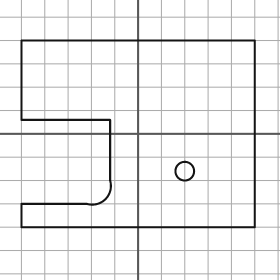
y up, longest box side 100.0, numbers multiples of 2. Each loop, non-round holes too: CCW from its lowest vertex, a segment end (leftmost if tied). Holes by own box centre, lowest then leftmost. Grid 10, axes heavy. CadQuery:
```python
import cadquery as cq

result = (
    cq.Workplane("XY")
    .moveTo(-50.0, -40.0)
    .lineTo(50.0, -40.0)
    .lineTo(50.0, 40.0)
    .lineTo(-50.0, 40.0)
    .lineTo(-50.0, 6.0)
    .lineTo(-12.0, 6.0)
    .lineTo(-12.0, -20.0)
    .threePointArc((-14.0, -28.0), (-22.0, -30.0))
    .lineTo(-50.0, -30.0)
    .close()
    .moveTo(20.0, -16.0)
    .circle(4.0)
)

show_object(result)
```